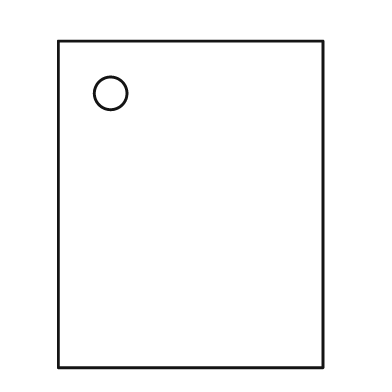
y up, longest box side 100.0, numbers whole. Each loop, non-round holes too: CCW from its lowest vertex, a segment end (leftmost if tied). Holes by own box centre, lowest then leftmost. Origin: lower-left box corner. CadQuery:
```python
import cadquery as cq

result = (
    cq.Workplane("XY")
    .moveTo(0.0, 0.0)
    .lineTo(81.0, 0.0)
    .lineTo(81.0, 100.0)
    .lineTo(0.0, 100.0)
    .close()
    .moveTo(16.0, 84.0)
    .circle(5.0)
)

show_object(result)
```